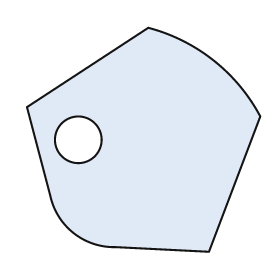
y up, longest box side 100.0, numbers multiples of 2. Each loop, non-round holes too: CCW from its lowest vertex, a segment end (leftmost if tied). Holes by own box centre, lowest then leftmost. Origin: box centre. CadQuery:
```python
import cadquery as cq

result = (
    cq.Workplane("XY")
    .moveTo(28.0, -48.0)
    .lineTo(50.0, 10.0)
    .threePointArc((30.0, 34.0), (2.0, 48.0))
    .lineTo(-50.0, 14.0)
    .lineTo(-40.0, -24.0)
    .threePointArc((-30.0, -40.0), (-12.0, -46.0))
    .close()
    .moveTo(-28.0, 0.0)
    .circle(10.0)
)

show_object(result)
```